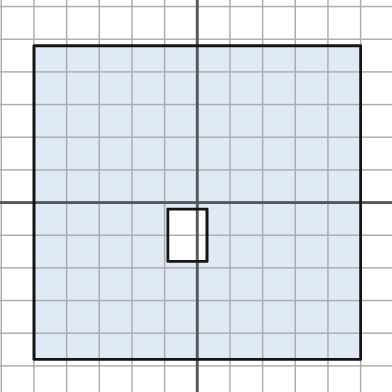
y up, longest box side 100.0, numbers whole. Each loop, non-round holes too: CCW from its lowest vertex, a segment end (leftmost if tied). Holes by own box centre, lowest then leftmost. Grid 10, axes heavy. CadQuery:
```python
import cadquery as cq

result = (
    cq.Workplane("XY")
    .moveTo(-50.0, -48.0)
    .lineTo(50.0, -48.0)
    .lineTo(50.0, 48.0)
    .lineTo(-50.0, 48.0)
    .close()
    .moveTo(-9.0, -18.0)
    .lineTo(3.0, -18.0)
    .lineTo(3.0, -2.0)
    .lineTo(-9.0, -2.0)
    .close()
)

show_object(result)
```